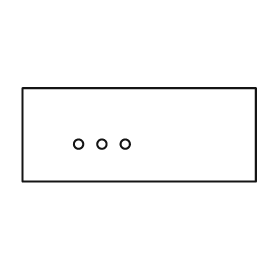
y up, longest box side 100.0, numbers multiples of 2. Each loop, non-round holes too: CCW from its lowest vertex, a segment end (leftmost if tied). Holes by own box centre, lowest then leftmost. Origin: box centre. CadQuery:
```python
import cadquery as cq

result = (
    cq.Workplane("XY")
    .moveTo(-50.0, -20.0)
    .lineTo(50.0, -20.0)
    .lineTo(50.0, 20.0)
    .lineTo(-50.0, 20.0)
    .close()
    .moveTo(-26.0, -4.0)
    .circle(2.0)
    .moveTo(-16.0, -4.0)
    .circle(2.0)
    .moveTo(-6.0, -4.0)
    .circle(2.0)
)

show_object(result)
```